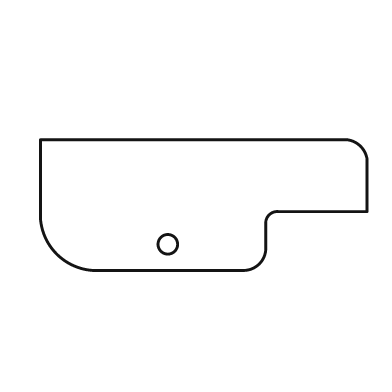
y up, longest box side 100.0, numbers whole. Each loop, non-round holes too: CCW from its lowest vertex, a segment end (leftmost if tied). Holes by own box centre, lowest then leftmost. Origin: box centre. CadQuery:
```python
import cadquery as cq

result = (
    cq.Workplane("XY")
    .moveTo(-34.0, -20.0)
    .lineTo(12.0, -20.0)
    .threePointArc((17.0, -18.0), (19.0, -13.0))
    .lineTo(19.0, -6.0)
    .threePointArc((20.0, -3.0), (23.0, -2.0))
    .lineTo(50.0, -2.0)
    .lineTo(50.0, 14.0)
    .threePointArc((48.0, 18.0), (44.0, 20.0))
    .lineTo(-50.0, 20.0)
    .lineTo(-50.0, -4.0)
    .threePointArc((-45.0, -15.0), (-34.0, -20.0))
    .close()
    .moveTo(-11.0, -12.0)
    .circle(3.0)
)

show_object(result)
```